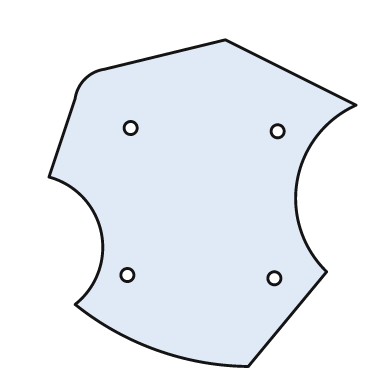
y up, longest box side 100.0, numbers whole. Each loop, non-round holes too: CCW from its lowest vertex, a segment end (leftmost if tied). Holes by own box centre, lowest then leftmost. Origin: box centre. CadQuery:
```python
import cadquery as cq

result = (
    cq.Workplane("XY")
    .moveTo(14.0, -50.0)
    .lineTo(38.0, -21.0)
    .threePointArc((29.0, 7.0), (47.0, 30.0))
    .lineTo(7.0, 50.0)
    .lineTo(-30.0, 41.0)
    .threePointArc((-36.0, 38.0), (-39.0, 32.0))
    .lineTo(-47.0, 8.0)
    .threePointArc((-31.0, -9.0), (-39.0, -31.0))
    .threePointArc((-14.0, -45.0), (14.0, -50.0))
    .close()
    .moveTo(22.0, -23.0)
    .circle(2.0)
    .moveTo(-23.0, -22.0)
    .circle(2.0)
    .moveTo(23.0, 22.0)
    .circle(2.0)
    .moveTo(-22.0, 23.0)
    .circle(2.0)
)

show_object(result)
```